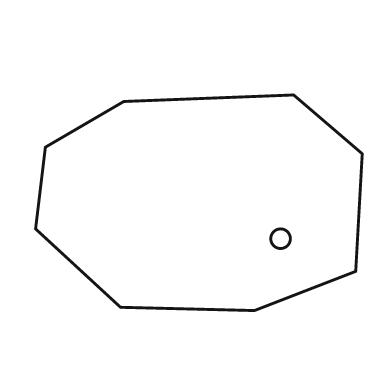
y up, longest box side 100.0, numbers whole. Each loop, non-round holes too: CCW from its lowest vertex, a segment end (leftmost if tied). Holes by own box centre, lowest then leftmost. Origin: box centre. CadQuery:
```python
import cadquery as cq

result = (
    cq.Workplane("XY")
    .moveTo(17.0, -33.0)
    .lineTo(48.0, -21.0)
    .lineTo(50.0, 15.0)
    .lineTo(29.0, 33.0)
    .lineTo(-23.0, 31.0)
    .lineTo(-47.0, 17.0)
    .lineTo(-50.0, -8.0)
    .lineTo(-24.0, -32.0)
    .close()
    .moveTo(25.0, -11.0)
    .circle(3.0)
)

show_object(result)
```